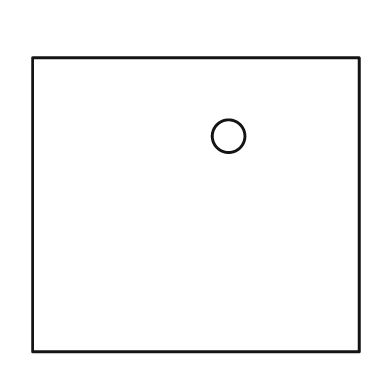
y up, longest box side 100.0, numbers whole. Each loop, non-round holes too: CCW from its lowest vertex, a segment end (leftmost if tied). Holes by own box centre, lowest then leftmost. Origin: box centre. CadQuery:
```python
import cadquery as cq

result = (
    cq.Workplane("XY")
    .moveTo(-50.0, -45.0)
    .lineTo(50.0, -45.0)
    .lineTo(50.0, 45.0)
    .lineTo(-50.0, 45.0)
    .close()
    .moveTo(10.0, 21.0)
    .circle(5.0)
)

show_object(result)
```